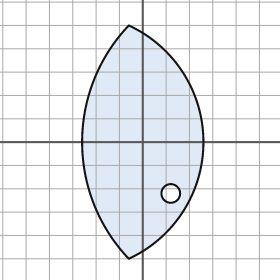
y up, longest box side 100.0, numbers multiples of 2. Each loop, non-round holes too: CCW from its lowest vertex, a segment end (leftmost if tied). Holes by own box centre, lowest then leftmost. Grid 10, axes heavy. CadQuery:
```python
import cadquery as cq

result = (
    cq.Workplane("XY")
    .moveTo(-6.0, -50.0)
    .threePointArc((26.0, 0.0), (-6.0, 50.0))
    .threePointArc((-26.0, 0.0), (-6.0, -50.0))
    .close()
    .moveTo(12.0, -22.0)
    .circle(4.0)
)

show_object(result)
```